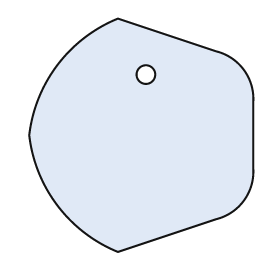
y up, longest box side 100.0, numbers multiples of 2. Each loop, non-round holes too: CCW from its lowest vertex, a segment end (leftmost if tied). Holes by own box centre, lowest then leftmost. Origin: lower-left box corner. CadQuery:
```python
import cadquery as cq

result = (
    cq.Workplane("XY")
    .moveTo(38.0, 0.0)
    .lineTo(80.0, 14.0)
    .threePointArc((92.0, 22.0), (96.0, 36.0))
    .lineTo(96.0, 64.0)
    .threePointArc((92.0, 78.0), (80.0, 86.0))
    .lineTo(38.0, 100.0)
    .threePointArc((12.0, 80.0), (0.0, 50.0))
    .threePointArc((12.0, 20.0), (38.0, 0.0))
    .close()
    .moveTo(50.0, 76.0)
    .circle(4.0)
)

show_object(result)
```